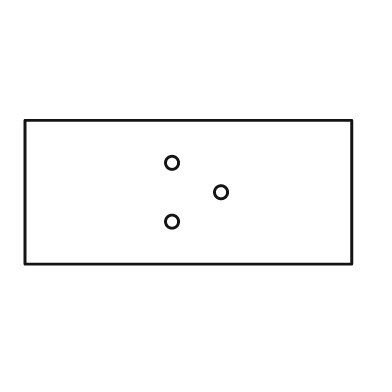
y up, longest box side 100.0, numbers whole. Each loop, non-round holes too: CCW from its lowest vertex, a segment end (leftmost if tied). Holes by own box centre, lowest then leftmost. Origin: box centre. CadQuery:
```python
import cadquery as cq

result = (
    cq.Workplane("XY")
    .moveTo(-50.0, -22.0)
    .lineTo(50.0, -22.0)
    .lineTo(50.0, 22.0)
    .lineTo(-50.0, 22.0)
    .close()
    .moveTo(-5.0, -9.0)
    .circle(2.0)
    .moveTo(10.0, 0.0)
    .circle(2.0)
    .moveTo(-5.0, 9.0)
    .circle(2.0)
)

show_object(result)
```